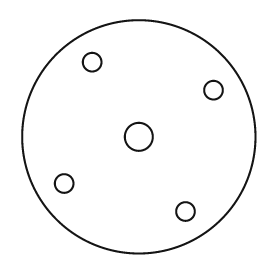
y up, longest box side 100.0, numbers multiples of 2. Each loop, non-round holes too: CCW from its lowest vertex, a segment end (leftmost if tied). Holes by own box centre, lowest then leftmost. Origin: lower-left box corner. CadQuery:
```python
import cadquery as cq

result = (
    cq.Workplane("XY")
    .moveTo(50.0, 50.0)
    .circle(50.0)
    .moveTo(70.0, 18.0)
    .circle(4.0)
    .moveTo(18.0, 30.0)
    .circle(4.0)
    .moveTo(50.0, 50.0)
    .circle(6.0)
    .moveTo(82.0, 70.0)
    .circle(4.0)
    .moveTo(30.0, 82.0)
    .circle(4.0)
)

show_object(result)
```